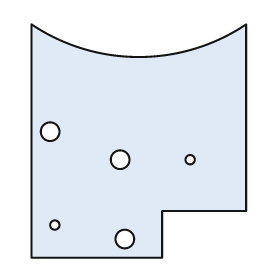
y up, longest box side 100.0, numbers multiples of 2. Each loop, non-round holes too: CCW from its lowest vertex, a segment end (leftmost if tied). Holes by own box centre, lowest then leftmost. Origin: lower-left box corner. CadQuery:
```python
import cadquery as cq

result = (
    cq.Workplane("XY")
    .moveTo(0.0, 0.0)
    .lineTo(56.0, 0.0)
    .lineTo(56.0, 20.0)
    .lineTo(92.0, 20.0)
    .lineTo(92.0, 100.0)
    .threePointArc((46.0, 86.0), (0.0, 100.0))
    .close()
    .moveTo(40.0, 8.0)
    .circle(4.0)
    .moveTo(10.0, 14.0)
    .circle(2.0)
    .moveTo(38.0, 42.0)
    .circle(4.0)
    .moveTo(68.0, 42.0)
    .circle(2.0)
    .moveTo(8.0, 54.0)
    .circle(4.0)
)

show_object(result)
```